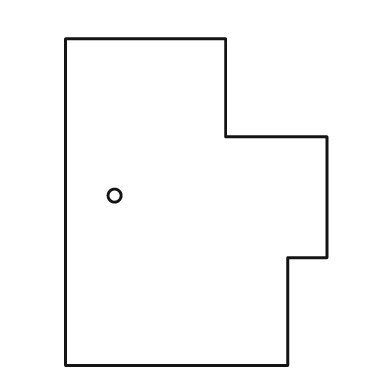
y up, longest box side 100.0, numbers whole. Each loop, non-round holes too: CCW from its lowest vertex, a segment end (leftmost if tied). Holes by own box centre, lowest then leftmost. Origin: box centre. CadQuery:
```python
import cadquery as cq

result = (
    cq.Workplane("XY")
    .moveTo(-40.0, -50.0)
    .lineTo(28.0, -50.0)
    .lineTo(28.0, -17.0)
    .lineTo(40.0, -17.0)
    .lineTo(40.0, 20.0)
    .lineTo(9.0, 20.0)
    .lineTo(9.0, 50.0)
    .lineTo(-40.0, 50.0)
    .close()
    .moveTo(-25.0, 2.0)
    .circle(2.0)
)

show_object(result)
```